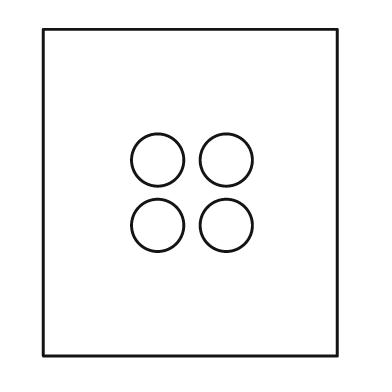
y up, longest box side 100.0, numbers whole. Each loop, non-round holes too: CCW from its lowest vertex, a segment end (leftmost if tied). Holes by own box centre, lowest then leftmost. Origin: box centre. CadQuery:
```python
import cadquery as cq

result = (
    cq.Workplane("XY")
    .moveTo(-45.0, -50.0)
    .lineTo(45.0, -50.0)
    .lineTo(45.0, 50.0)
    .lineTo(-45.0, 50.0)
    .close()
    .moveTo(-10.0, -10.0)
    .circle(8.0)
    .moveTo(11.0, -10.0)
    .circle(8.0)
    .moveTo(-10.0, 10.0)
    .circle(8.0)
    .moveTo(11.0, 10.0)
    .circle(8.0)
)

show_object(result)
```